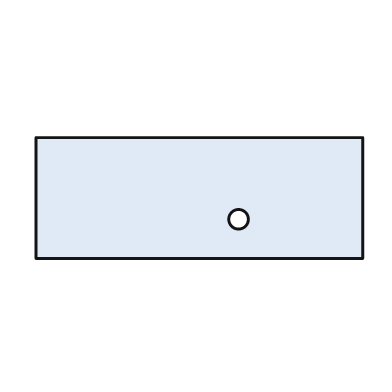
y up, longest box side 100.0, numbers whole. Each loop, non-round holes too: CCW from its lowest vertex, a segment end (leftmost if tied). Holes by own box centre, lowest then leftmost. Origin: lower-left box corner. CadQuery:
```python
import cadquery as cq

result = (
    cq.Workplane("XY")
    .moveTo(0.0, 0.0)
    .lineTo(100.0, 0.0)
    .lineTo(100.0, 37.0)
    .lineTo(0.0, 37.0)
    .close()
    .moveTo(62.0, 12.0)
    .circle(3.0)
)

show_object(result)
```